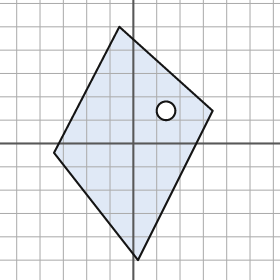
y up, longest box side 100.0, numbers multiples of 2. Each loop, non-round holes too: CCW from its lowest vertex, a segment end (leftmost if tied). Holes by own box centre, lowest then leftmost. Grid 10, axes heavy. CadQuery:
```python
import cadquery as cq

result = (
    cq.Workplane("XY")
    .moveTo(2.0, -50.0)
    .lineTo(34.0, 14.0)
    .lineTo(-6.0, 50.0)
    .lineTo(-34.0, -4.0)
    .close()
    .moveTo(14.0, 14.0)
    .circle(4.0)
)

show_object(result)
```